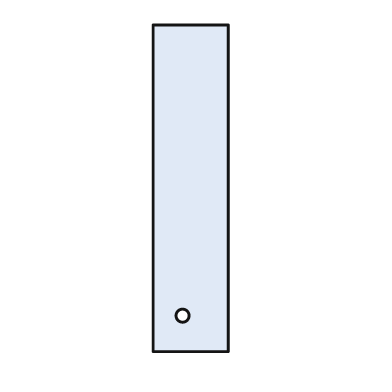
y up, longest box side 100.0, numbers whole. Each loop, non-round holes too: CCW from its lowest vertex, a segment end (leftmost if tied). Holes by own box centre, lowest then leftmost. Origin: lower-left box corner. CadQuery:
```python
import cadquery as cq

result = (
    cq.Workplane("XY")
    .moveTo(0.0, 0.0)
    .lineTo(23.0, 0.0)
    .lineTo(23.0, 100.0)
    .lineTo(0.0, 100.0)
    .close()
    .moveTo(9.0, 11.0)
    .circle(2.0)
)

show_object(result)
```